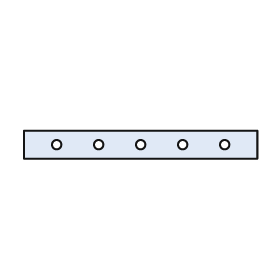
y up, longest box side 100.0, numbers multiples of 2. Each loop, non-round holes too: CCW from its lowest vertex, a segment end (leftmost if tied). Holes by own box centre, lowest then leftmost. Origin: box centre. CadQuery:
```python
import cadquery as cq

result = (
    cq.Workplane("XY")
    .moveTo(-50.0, -6.0)
    .lineTo(50.0, -6.0)
    .lineTo(50.0, 6.0)
    .lineTo(-50.0, 6.0)
    .close()
    .moveTo(-36.0, 0.0)
    .circle(2.0)
    .moveTo(-18.0, 0.0)
    .circle(2.0)
    .moveTo(0.0, 0.0)
    .circle(2.0)
    .moveTo(18.0, 0.0)
    .circle(2.0)
    .moveTo(36.0, 0.0)
    .circle(2.0)
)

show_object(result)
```